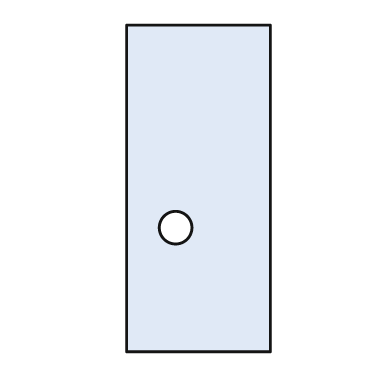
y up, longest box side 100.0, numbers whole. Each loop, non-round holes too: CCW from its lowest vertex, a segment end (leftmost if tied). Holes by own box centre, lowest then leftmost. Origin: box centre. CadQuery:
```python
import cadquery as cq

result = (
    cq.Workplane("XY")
    .moveTo(-22.0, -50.0)
    .lineTo(22.0, -50.0)
    .lineTo(22.0, 50.0)
    .lineTo(-22.0, 50.0)
    .close()
    .moveTo(-7.0, -12.0)
    .circle(5.0)
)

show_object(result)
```